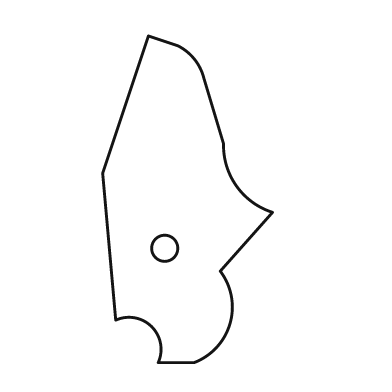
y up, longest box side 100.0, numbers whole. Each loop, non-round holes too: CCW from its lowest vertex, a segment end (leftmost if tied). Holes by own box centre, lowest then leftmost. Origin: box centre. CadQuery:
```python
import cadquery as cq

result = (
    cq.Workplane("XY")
    .moveTo(-9.0, -50.0)
    .lineTo(2.0, -50.0)
    .threePointArc((13.0, -38.0), (10.0, -22.0))
    .lineTo(26.0, -4.0)
    .threePointArc((15.0, 4.0), (11.0, 17.0))
    .lineTo(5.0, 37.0)
    .threePointArc((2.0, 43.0), (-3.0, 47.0))
    .lineTo(-12.0, 50.0)
    .lineTo(-26.0, 8.0)
    .lineTo(-22.0, -37.0)
    .threePointArc((-11.0, -39.0), (-9.0, -50.0))
    .close()
    .moveTo(-7.0, -15.0)
    .circle(4.0)
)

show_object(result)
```